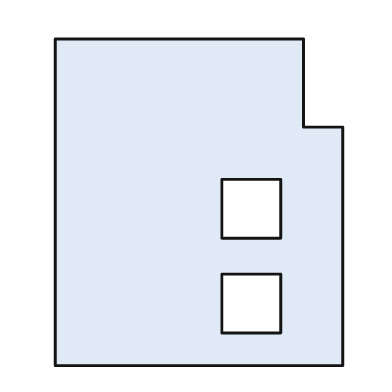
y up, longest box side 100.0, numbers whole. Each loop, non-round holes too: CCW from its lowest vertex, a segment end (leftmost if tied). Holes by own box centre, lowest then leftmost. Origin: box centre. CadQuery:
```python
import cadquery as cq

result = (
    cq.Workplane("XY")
    .moveTo(-44.0, -50.0)
    .lineTo(44.0, -50.0)
    .lineTo(44.0, 23.0)
    .lineTo(32.0, 23.0)
    .lineTo(32.0, 50.0)
    .lineTo(-44.0, 50.0)
    .close()
    .moveTo(7.0, -40.0)
    .lineTo(25.0, -40.0)
    .lineTo(25.0, -22.0)
    .lineTo(7.0, -22.0)
    .close()
    .moveTo(7.0, -11.0)
    .lineTo(25.0, -11.0)
    .lineTo(25.0, 7.0)
    .lineTo(7.0, 7.0)
    .close()
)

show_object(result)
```